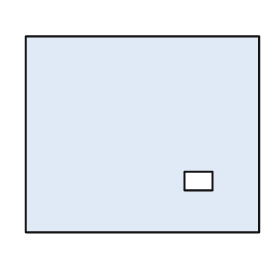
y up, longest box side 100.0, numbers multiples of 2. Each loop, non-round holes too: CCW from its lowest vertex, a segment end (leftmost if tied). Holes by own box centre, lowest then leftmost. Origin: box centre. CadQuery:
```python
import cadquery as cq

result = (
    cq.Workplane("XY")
    .moveTo(-50.0, -42.0)
    .lineTo(50.0, -42.0)
    .lineTo(50.0, 42.0)
    .lineTo(-50.0, 42.0)
    .close()
    .moveTo(18.0, -24.0)
    .lineTo(30.0, -24.0)
    .lineTo(30.0, -16.0)
    .lineTo(18.0, -16.0)
    .close()
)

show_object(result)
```